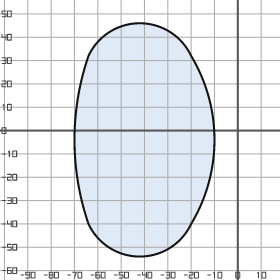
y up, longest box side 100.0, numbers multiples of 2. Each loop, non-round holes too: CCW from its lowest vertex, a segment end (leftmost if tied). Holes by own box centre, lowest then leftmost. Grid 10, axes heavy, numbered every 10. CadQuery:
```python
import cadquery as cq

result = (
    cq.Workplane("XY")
    .moveTo(-64.0, -40.0)
    .threePointArc((-42.0, -54.0), (-20.0, -40.0))
    .threePointArc((-10.0, -4.0), (-20.0, 32.0))
    .threePointArc((-42.0, 46.0), (-64.0, 32.0))
    .threePointArc((-70.0, -4.0), (-64.0, -40.0))
    .close()
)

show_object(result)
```